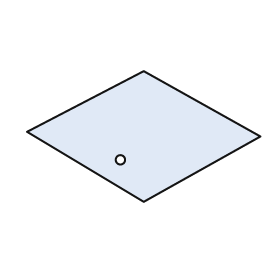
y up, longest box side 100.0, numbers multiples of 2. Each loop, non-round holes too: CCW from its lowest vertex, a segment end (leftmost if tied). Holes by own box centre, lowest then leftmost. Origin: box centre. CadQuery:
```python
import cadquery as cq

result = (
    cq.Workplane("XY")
    .moveTo(0.0, -28.0)
    .lineTo(50.0, 0.0)
    .lineTo(0.0, 28.0)
    .lineTo(-50.0, 2.0)
    .close()
    .moveTo(-10.0, -10.0)
    .circle(2.0)
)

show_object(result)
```